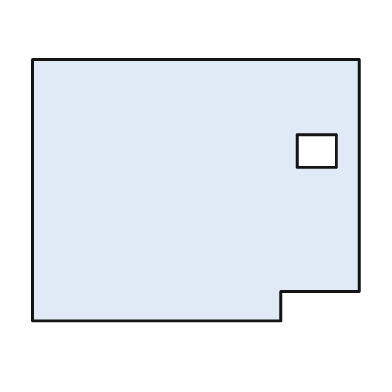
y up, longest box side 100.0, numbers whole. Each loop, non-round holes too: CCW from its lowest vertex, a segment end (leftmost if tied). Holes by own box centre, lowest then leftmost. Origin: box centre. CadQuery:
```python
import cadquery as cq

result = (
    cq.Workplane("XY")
    .moveTo(-50.0, -40.0)
    .lineTo(26.0, -40.0)
    .lineTo(26.0, -31.0)
    .lineTo(50.0, -31.0)
    .lineTo(50.0, 40.0)
    .lineTo(-50.0, 40.0)
    .close()
    .moveTo(31.0, 7.0)
    .lineTo(43.0, 7.0)
    .lineTo(43.0, 17.0)
    .lineTo(31.0, 17.0)
    .close()
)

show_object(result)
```